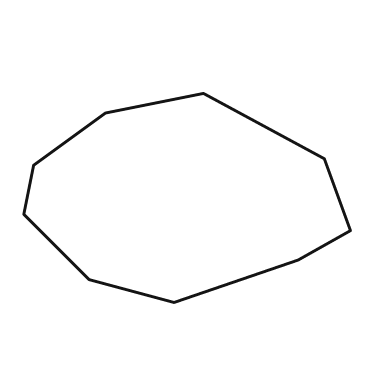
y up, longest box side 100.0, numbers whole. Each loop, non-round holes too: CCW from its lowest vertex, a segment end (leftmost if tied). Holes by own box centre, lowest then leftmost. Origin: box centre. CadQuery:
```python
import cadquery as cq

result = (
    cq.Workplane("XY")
    .moveTo(-4.0, -32.0)
    .lineTo(34.0, -19.0)
    .lineTo(50.0, -10.0)
    .lineTo(42.0, 12.0)
    .lineTo(5.0, 32.0)
    .lineTo(-25.0, 26.0)
    .lineTo(-47.0, 10.0)
    .lineTo(-50.0, -5.0)
    .lineTo(-30.0, -25.0)
    .close()
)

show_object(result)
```